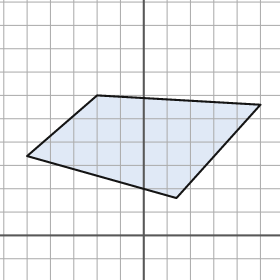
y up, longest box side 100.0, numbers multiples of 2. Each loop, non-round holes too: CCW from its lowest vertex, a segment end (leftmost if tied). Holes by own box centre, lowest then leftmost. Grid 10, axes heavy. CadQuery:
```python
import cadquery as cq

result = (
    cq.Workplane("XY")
    .moveTo(14.0, 16.0)
    .lineTo(50.0, 56.0)
    .lineTo(-20.0, 60.0)
    .lineTo(-50.0, 34.0)
    .close()
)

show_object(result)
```